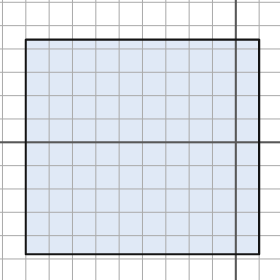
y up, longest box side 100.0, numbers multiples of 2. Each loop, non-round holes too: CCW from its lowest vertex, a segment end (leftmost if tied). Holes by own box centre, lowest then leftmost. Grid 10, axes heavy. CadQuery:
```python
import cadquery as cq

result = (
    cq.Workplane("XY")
    .moveTo(-90.0, -48.0)
    .lineTo(10.0, -48.0)
    .lineTo(10.0, 44.0)
    .lineTo(-90.0, 44.0)
    .close()
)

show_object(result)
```